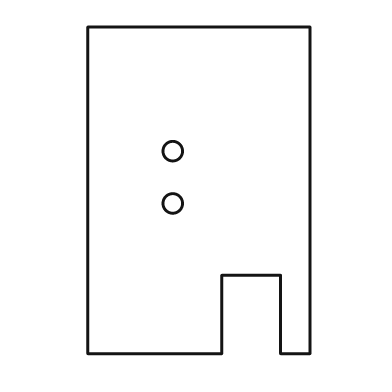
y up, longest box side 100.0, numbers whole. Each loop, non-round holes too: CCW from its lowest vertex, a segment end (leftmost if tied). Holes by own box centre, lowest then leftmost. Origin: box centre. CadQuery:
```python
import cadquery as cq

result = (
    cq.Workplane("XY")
    .moveTo(-34.0, -50.0)
    .lineTo(7.0, -50.0)
    .lineTo(7.0, -26.0)
    .lineTo(25.0, -26.0)
    .lineTo(25.0, -50.0)
    .lineTo(34.0, -50.0)
    .lineTo(34.0, 50.0)
    .lineTo(-34.0, 50.0)
    .close()
    .moveTo(-8.0, -4.0)
    .circle(3.0)
    .moveTo(-8.0, 12.0)
    .circle(3.0)
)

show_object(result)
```